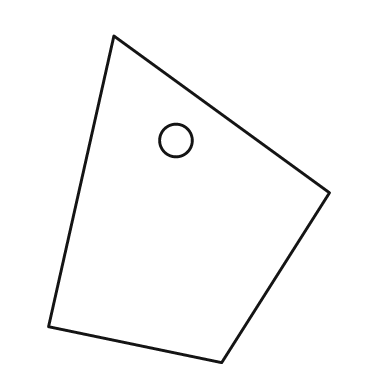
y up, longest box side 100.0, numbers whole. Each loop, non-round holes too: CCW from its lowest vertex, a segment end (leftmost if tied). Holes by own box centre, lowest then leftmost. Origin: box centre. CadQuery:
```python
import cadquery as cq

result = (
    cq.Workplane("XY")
    .moveTo(10.0, -50.0)
    .lineTo(43.0, 2.0)
    .lineTo(-23.0, 50.0)
    .lineTo(-43.0, -39.0)
    .close()
    .moveTo(-4.0, 18.0)
    .circle(5.0)
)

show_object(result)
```